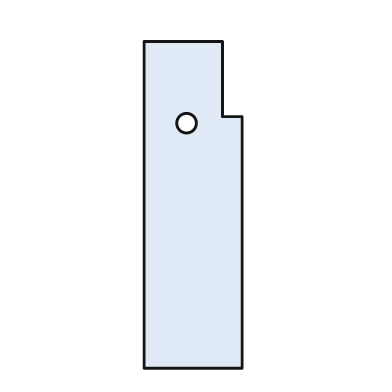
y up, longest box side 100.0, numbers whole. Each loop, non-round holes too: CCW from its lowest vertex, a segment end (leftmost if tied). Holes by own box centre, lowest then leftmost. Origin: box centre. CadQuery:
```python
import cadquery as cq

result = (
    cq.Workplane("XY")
    .moveTo(-15.0, -50.0)
    .lineTo(15.0, -50.0)
    .lineTo(15.0, 27.0)
    .lineTo(9.0, 27.0)
    .lineTo(9.0, 50.0)
    .lineTo(-15.0, 50.0)
    .close()
    .moveTo(-2.0, 25.0)
    .circle(3.0)
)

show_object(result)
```